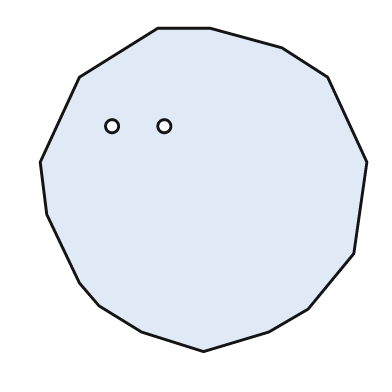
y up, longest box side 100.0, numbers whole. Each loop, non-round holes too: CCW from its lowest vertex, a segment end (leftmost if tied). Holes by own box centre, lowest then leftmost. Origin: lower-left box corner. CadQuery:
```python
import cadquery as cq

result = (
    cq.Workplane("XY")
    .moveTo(50.0, 0.0)
    .lineTo(70.0, 6.0)
    .lineTo(82.0, 13.0)
    .lineTo(96.0, 30.0)
    .lineTo(100.0, 58.0)
    .lineTo(88.0, 84.0)
    .lineTo(74.0, 93.0)
    .lineTo(52.0, 99.0)
    .lineTo(36.0, 99.0)
    .lineTo(12.0, 84.0)
    .lineTo(0.0, 58.0)
    .lineTo(2.0, 42.0)
    .lineTo(12.0, 21.0)
    .lineTo(18.0, 14.0)
    .lineTo(31.0, 6.0)
    .close()
    .moveTo(22.0, 69.0)
    .circle(2.0)
    .moveTo(38.0, 69.0)
    .circle(2.0)
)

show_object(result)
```